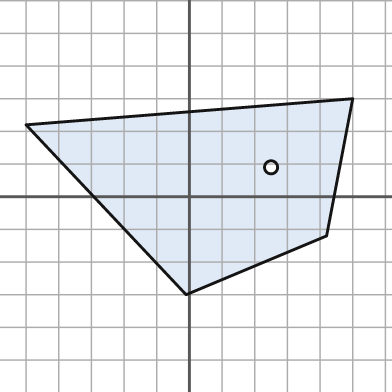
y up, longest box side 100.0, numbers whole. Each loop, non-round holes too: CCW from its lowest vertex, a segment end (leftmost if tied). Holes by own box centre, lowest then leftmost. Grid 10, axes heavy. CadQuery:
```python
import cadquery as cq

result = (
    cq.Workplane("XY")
    .moveTo(-1.0, -30.0)
    .lineTo(42.0, -12.0)
    .lineTo(50.0, 30.0)
    .lineTo(-50.0, 22.0)
    .close()
    .moveTo(25.0, 9.0)
    .circle(2.0)
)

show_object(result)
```